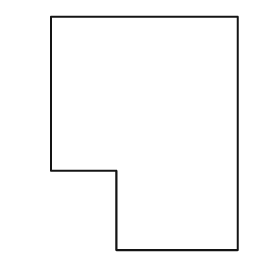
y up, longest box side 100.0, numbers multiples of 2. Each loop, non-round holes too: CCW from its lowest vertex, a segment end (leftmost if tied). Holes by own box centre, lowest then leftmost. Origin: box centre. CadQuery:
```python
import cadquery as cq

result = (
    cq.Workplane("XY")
    .moveTo(-12.0, -50.0)
    .lineTo(40.0, -50.0)
    .lineTo(40.0, 50.0)
    .lineTo(-40.0, 50.0)
    .lineTo(-40.0, -16.0)
    .lineTo(-12.0, -16.0)
    .close()
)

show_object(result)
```